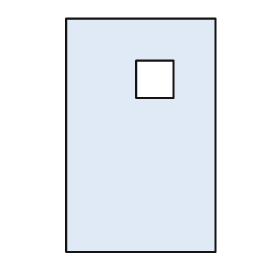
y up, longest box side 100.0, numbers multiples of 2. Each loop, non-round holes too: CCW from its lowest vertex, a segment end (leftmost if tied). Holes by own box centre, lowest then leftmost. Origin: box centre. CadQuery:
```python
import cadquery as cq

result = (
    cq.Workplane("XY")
    .moveTo(-32.0, -50.0)
    .lineTo(32.0, -50.0)
    .lineTo(32.0, 50.0)
    .lineTo(-32.0, 50.0)
    .close()
    .moveTo(-2.0, 16.0)
    .lineTo(14.0, 16.0)
    .lineTo(14.0, 32.0)
    .lineTo(-2.0, 32.0)
    .close()
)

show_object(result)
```